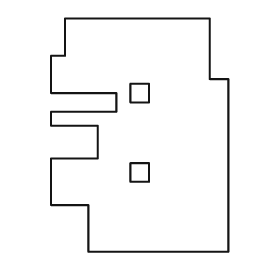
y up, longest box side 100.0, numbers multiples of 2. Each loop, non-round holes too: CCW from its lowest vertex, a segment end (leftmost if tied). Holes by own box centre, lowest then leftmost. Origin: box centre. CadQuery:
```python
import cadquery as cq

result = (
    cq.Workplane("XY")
    .moveTo(-22.0, -50.0)
    .lineTo(38.0, -50.0)
    .lineTo(38.0, 24.0)
    .lineTo(30.0, 24.0)
    .lineTo(30.0, 50.0)
    .lineTo(-32.0, 50.0)
    .lineTo(-32.0, 34.0)
    .lineTo(-38.0, 34.0)
    .lineTo(-38.0, 18.0)
    .lineTo(-10.0, 18.0)
    .lineTo(-10.0, 10.0)
    .lineTo(-38.0, 10.0)
    .lineTo(-38.0, 4.0)
    .lineTo(-18.0, 4.0)
    .lineTo(-18.0, -10.0)
    .lineTo(-38.0, -10.0)
    .lineTo(-38.0, -30.0)
    .lineTo(-22.0, -30.0)
    .close()
    .moveTo(-4.0, -20.0)
    .lineTo(4.0, -20.0)
    .lineTo(4.0, -12.0)
    .lineTo(-4.0, -12.0)
    .close()
    .moveTo(-4.0, 14.0)
    .lineTo(4.0, 14.0)
    .lineTo(4.0, 22.0)
    .lineTo(-4.0, 22.0)
    .close()
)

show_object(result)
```